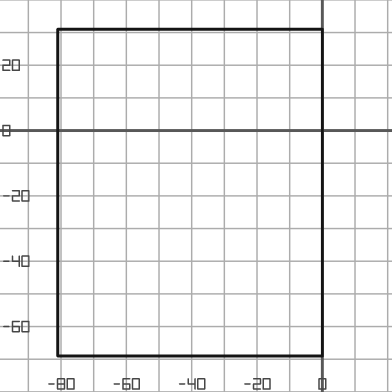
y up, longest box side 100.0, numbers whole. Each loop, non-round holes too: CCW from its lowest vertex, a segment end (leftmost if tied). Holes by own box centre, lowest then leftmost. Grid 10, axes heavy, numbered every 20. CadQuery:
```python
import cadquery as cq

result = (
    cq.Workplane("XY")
    .moveTo(-81.0, -69.0)
    .lineTo(0.0, -69.0)
    .lineTo(0.0, 31.0)
    .lineTo(-81.0, 31.0)
    .close()
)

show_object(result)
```